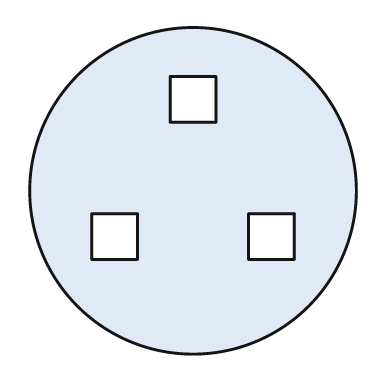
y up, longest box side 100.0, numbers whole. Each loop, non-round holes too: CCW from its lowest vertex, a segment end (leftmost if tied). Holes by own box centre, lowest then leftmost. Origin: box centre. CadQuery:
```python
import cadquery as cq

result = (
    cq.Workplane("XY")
    .moveTo(0.0, 0.0)
    .circle(50.0)
    .moveTo(-31.0, -21.0)
    .lineTo(-17.0, -21.0)
    .lineTo(-17.0, -7.0)
    .lineTo(-31.0, -7.0)
    .close()
    .moveTo(17.0, -21.0)
    .lineTo(31.0, -21.0)
    .lineTo(31.0, -7.0)
    .lineTo(17.0, -7.0)
    .close()
    .moveTo(-7.0, 21.0)
    .lineTo(7.0, 21.0)
    .lineTo(7.0, 35.0)
    .lineTo(-7.0, 35.0)
    .close()
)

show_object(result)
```